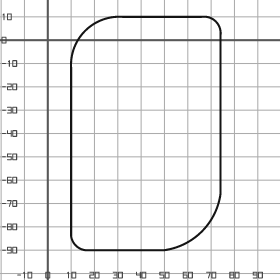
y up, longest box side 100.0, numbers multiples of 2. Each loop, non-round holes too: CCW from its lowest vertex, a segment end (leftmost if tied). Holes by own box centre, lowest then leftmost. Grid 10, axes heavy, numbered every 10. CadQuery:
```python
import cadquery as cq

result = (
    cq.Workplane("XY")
    .moveTo(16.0, -90.0)
    .lineTo(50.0, -90.0)
    .threePointArc((66.0, -82.0), (74.0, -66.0))
    .lineTo(74.0, 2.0)
    .threePointArc((72.0, 8.0), (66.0, 10.0))
    .lineTo(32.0, 10.0)
    .threePointArc((16.0, 4.0), (10.0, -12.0))
    .lineTo(10.0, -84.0)
    .threePointArc((12.0, -88.0), (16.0, -90.0))
    .close()
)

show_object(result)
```